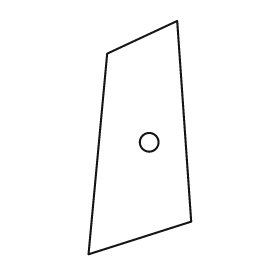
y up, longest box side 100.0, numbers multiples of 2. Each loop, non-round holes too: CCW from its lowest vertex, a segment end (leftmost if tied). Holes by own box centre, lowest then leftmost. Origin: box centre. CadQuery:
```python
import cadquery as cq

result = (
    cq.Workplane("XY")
    .moveTo(-22.0, -50.0)
    .lineTo(22.0, -36.0)
    .lineTo(16.0, 50.0)
    .lineTo(-14.0, 36.0)
    .close()
    .moveTo(4.0, -2.0)
    .circle(4.0)
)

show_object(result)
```